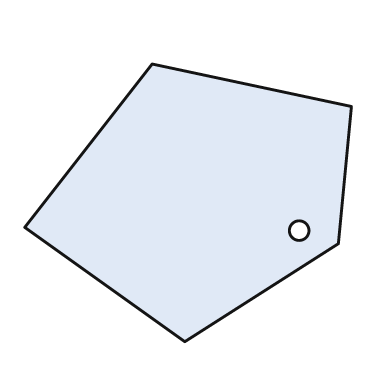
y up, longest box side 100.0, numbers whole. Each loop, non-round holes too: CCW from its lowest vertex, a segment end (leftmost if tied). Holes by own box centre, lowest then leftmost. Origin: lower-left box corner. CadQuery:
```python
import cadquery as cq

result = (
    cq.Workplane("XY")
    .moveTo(49.0, 0.0)
    .lineTo(96.0, 30.0)
    .lineTo(100.0, 72.0)
    .lineTo(39.0, 85.0)
    .lineTo(0.0, 35.0)
    .close()
    .moveTo(84.0, 34.0)
    .circle(3.0)
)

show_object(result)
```